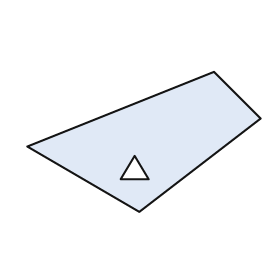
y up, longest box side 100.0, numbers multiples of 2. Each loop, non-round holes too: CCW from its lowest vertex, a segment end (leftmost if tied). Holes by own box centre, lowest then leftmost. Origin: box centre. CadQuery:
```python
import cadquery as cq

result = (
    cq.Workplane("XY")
    .moveTo(-2.0, -30.0)
    .lineTo(50.0, 10.0)
    .lineTo(30.0, 30.0)
    .lineTo(-50.0, -2.0)
    .close()
    .moveTo(-10.0, -16.0)
    .lineTo(2.0, -16.0)
    .lineTo(-4.0, -6.0)
    .close()
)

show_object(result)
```